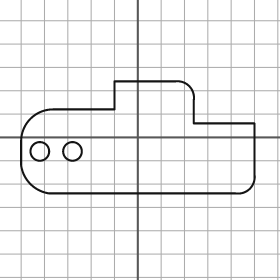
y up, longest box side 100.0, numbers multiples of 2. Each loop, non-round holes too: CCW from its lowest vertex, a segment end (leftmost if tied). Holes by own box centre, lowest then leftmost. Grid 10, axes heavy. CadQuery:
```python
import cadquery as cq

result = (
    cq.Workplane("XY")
    .moveTo(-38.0, -24.0)
    .lineTo(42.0, -24.0)
    .threePointArc((48.0, -22.0), (50.0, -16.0))
    .lineTo(50.0, 6.0)
    .lineTo(24.0, 6.0)
    .lineTo(24.0, 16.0)
    .threePointArc((22.0, 22.0), (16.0, 24.0))
    .lineTo(-10.0, 24.0)
    .lineTo(-10.0, 12.0)
    .lineTo(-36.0, 12.0)
    .threePointArc((-46.0, 8.0), (-50.0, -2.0))
    .lineTo(-50.0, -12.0)
    .threePointArc((-46.0, -20.0), (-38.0, -24.0))
    .close()
    .moveTo(-42.0, -6.0)
    .circle(4.0)
    .moveTo(-28.0, -6.0)
    .circle(4.0)
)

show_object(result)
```